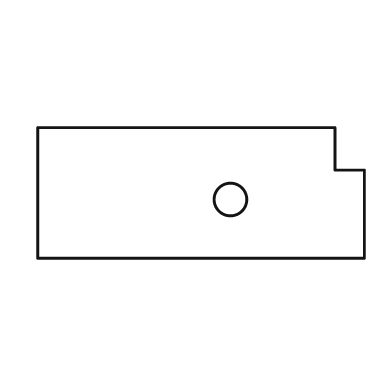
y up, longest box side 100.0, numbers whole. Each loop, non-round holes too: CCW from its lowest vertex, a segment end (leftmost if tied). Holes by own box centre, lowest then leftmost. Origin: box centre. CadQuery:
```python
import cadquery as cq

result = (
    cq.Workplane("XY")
    .moveTo(-50.0, -20.0)
    .lineTo(50.0, -20.0)
    .lineTo(50.0, 7.0)
    .lineTo(41.0, 7.0)
    .lineTo(41.0, 20.0)
    .lineTo(-50.0, 20.0)
    .close()
    .moveTo(9.0, -2.0)
    .circle(5.0)
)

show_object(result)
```